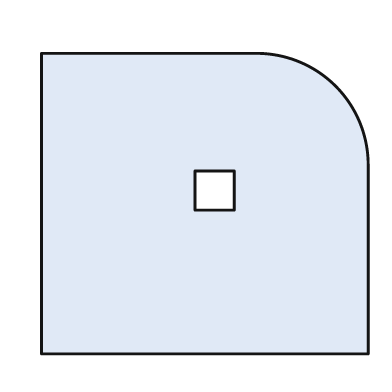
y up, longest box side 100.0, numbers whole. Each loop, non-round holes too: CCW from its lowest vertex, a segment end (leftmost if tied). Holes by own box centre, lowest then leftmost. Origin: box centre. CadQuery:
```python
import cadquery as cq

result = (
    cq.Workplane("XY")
    .moveTo(-50.0, -46.0)
    .lineTo(50.0, -46.0)
    .lineTo(50.0, 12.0)
    .threePointArc((40.0, 36.0), (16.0, 46.0))
    .lineTo(-50.0, 46.0)
    .close()
    .moveTo(-3.0, -2.0)
    .lineTo(9.0, -2.0)
    .lineTo(9.0, 10.0)
    .lineTo(-3.0, 10.0)
    .close()
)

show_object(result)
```